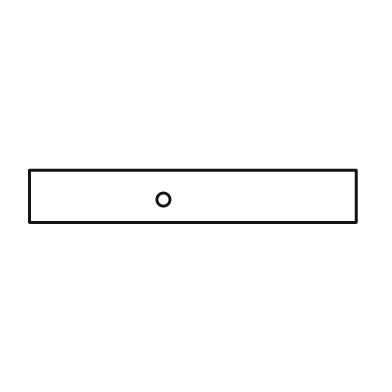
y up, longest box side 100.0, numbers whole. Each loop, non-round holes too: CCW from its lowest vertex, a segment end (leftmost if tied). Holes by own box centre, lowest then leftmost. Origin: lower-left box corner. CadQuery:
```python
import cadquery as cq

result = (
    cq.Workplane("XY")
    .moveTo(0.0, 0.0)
    .lineTo(100.0, 0.0)
    .lineTo(100.0, 16.0)
    .lineTo(0.0, 16.0)
    .close()
    .moveTo(41.0, 7.0)
    .circle(2.0)
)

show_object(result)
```